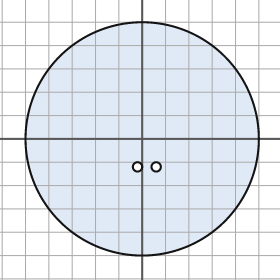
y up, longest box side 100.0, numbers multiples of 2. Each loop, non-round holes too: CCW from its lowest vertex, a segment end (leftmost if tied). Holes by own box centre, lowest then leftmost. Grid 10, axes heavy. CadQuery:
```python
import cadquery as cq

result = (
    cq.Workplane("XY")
    .moveTo(0.0, 0.0)
    .circle(50.0)
    .moveTo(-2.0, -12.0)
    .circle(2.0)
    .moveTo(6.0, -12.0)
    .circle(2.0)
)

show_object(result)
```